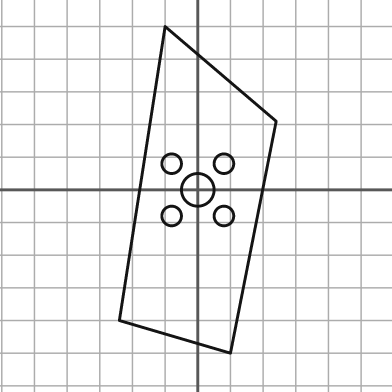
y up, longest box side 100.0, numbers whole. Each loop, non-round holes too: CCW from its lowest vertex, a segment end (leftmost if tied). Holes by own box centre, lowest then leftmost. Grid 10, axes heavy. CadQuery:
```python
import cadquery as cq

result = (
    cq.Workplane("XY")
    .moveTo(10.0, -50.0)
    .lineTo(24.0, 21.0)
    .lineTo(-10.0, 50.0)
    .lineTo(-24.0, -40.0)
    .close()
    .moveTo(-8.0, -8.0)
    .circle(3.0)
    .moveTo(8.0, -8.0)
    .circle(3.0)
    .moveTo(0.0, 0.0)
    .circle(5.0)
    .moveTo(-8.0, 8.0)
    .circle(3.0)
    .moveTo(8.0, 8.0)
    .circle(3.0)
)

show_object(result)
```